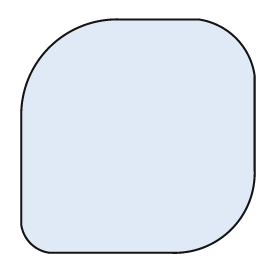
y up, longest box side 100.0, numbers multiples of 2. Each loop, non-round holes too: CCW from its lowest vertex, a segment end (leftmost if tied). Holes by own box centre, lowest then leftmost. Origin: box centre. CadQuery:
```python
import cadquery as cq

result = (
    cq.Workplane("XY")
    .moveTo(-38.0, -50.0)
    .lineTo(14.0, -50.0)
    .threePointArc((40.0, -40.0), (50.0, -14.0))
    .lineTo(50.0, 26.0)
    .threePointArc((42.0, 42.0), (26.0, 50.0))
    .lineTo(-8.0, 50.0)
    .threePointArc((-38.0, 38.0), (-50.0, 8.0))
    .lineTo(-50.0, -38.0)
    .threePointArc((-46.0, -46.0), (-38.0, -50.0))
    .close()
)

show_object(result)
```